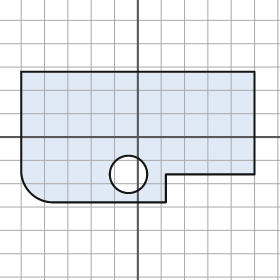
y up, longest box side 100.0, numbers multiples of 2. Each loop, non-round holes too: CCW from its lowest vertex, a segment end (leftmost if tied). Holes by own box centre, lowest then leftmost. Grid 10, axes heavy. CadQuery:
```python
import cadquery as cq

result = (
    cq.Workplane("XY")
    .moveTo(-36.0, -28.0)
    .lineTo(12.0, -28.0)
    .lineTo(12.0, -16.0)
    .lineTo(50.0, -16.0)
    .lineTo(50.0, 28.0)
    .lineTo(-50.0, 28.0)
    .lineTo(-50.0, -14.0)
    .threePointArc((-46.0, -24.0), (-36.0, -28.0))
    .close()
    .moveTo(-4.0, -16.0)
    .circle(8.0)
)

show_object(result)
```